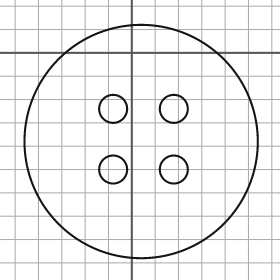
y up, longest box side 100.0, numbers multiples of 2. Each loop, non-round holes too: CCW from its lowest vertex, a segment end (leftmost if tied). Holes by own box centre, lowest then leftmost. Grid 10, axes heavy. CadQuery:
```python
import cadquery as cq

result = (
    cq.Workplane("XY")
    .moveTo(4.0, -38.0)
    .circle(50.0)
    .moveTo(-8.0, -50.0)
    .circle(6.0)
    .moveTo(18.0, -50.0)
    .circle(6.0)
    .moveTo(-8.0, -24.0)
    .circle(6.0)
    .moveTo(18.0, -24.0)
    .circle(6.0)
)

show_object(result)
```